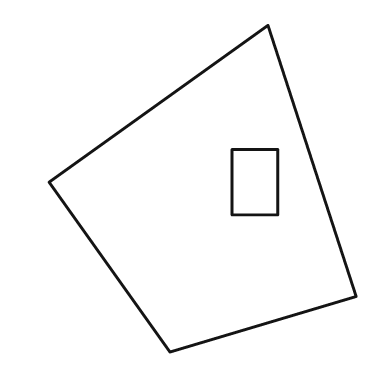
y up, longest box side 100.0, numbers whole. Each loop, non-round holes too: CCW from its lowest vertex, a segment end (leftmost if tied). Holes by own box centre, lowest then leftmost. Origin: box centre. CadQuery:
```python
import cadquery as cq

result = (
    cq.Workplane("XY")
    .moveTo(-10.0, -50.0)
    .lineTo(47.0, -33.0)
    .lineTo(20.0, 50.0)
    .lineTo(-47.0, 2.0)
    .close()
    .moveTo(9.0, -8.0)
    .lineTo(23.0, -8.0)
    .lineTo(23.0, 12.0)
    .lineTo(9.0, 12.0)
    .close()
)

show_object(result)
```